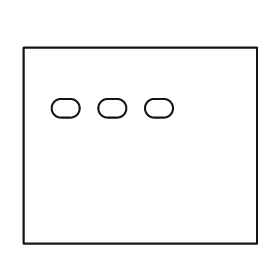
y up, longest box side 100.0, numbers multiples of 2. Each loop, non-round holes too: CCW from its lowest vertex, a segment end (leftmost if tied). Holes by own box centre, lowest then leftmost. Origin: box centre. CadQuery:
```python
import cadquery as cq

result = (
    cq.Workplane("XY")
    .moveTo(-50.0, -42.0)
    .lineTo(50.0, -42.0)
    .lineTo(50.0, 42.0)
    .lineTo(-50.0, 42.0)
    .close()
    .moveTo(-34.0, 12.0)
    .lineTo(-30.0, 12.0)
    .threePointArc((-26.0, 16.0), (-30.0, 20.0))
    .lineTo(-34.0, 20.0)
    .threePointArc((-38.0, 16.0), (-34.0, 12.0))
    .close()
    .moveTo(-14.0, 12.0)
    .lineTo(-10.0, 12.0)
    .threePointArc((-6.0, 16.0), (-10.0, 20.0))
    .lineTo(-14.0, 20.0)
    .threePointArc((-18.0, 16.0), (-14.0, 12.0))
    .close()
    .moveTo(6.0, 12.0)
    .lineTo(10.0, 12.0)
    .threePointArc((14.0, 16.0), (10.0, 20.0))
    .lineTo(6.0, 20.0)
    .threePointArc((2.0, 16.0), (6.0, 12.0))
    .close()
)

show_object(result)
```